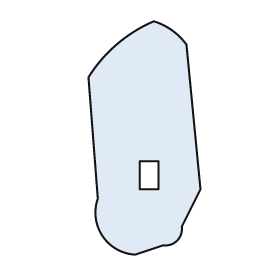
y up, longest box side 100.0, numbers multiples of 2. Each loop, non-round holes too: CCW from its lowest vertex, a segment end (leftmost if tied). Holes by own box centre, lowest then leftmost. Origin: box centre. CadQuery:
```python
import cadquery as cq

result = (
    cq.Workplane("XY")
    .moveTo(-4.0, -50.0)
    .lineTo(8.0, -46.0)
    .threePointArc((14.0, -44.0), (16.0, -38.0))
    .lineTo(24.0, -22.0)
    .lineTo(18.0, 40.0)
    .threePointArc((12.0, 46.0), (4.0, 50.0))
    .threePointArc((-12.0, 40.0), (-24.0, 26.0))
    .lineTo(-20.0, -26.0)
    .threePointArc((-18.0, -42.0), (-4.0, -50.0))
    .close()
    .moveTo(-2.0, -22.0)
    .lineTo(6.0, -22.0)
    .lineTo(6.0, -10.0)
    .lineTo(-2.0, -10.0)
    .close()
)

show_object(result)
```